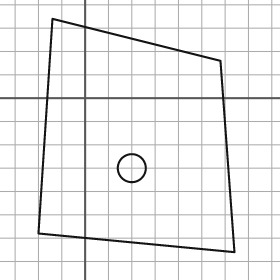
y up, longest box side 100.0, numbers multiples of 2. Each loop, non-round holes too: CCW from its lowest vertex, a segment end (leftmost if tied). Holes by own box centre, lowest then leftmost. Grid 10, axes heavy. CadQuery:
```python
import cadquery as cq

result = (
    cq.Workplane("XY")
    .moveTo(64.0, -66.0)
    .lineTo(58.0, 16.0)
    .lineTo(-14.0, 34.0)
    .lineTo(-20.0, -58.0)
    .close()
    .moveTo(20.0, -30.0)
    .circle(6.0)
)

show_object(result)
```